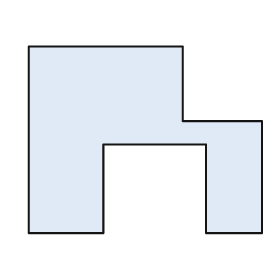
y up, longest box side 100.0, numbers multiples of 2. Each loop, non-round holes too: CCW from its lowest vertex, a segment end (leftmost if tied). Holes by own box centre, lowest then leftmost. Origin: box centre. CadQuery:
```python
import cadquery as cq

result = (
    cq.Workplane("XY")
    .moveTo(-50.0, -40.0)
    .lineTo(-18.0, -40.0)
    .lineTo(-18.0, -2.0)
    .lineTo(26.0, -2.0)
    .lineTo(26.0, -40.0)
    .lineTo(50.0, -40.0)
    .lineTo(50.0, 8.0)
    .lineTo(16.0, 8.0)
    .lineTo(16.0, 40.0)
    .lineTo(-50.0, 40.0)
    .close()
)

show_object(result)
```